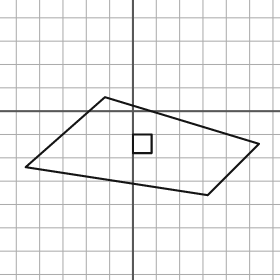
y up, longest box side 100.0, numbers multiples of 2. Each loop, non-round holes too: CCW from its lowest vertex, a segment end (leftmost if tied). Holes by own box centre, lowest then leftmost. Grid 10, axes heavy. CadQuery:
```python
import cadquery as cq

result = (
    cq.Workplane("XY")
    .moveTo(32.0, -36.0)
    .lineTo(54.0, -14.0)
    .lineTo(-12.0, 6.0)
    .lineTo(-46.0, -24.0)
    .close()
    .moveTo(0.0, -18.0)
    .lineTo(8.0, -18.0)
    .lineTo(8.0, -10.0)
    .lineTo(0.0, -10.0)
    .close()
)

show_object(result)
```